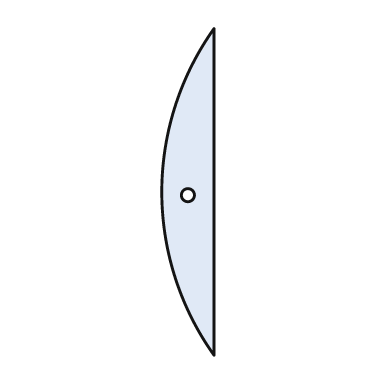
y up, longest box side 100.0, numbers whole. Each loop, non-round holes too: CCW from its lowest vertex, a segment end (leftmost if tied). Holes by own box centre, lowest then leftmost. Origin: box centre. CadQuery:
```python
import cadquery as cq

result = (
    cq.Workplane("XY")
    .moveTo(8.0, -50.0)
    .lineTo(8.0, 50.0)
    .threePointArc((-8.0, 0.0), (8.0, -50.0))
    .close()
    .moveTo(0.0, -1.0)
    .circle(2.0)
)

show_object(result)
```